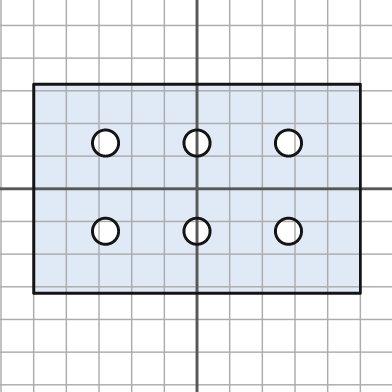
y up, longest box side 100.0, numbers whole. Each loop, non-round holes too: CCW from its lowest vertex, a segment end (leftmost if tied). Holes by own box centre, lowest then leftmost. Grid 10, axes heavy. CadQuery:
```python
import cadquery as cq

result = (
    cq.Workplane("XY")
    .moveTo(-50.0, -32.0)
    .lineTo(50.0, -32.0)
    .lineTo(50.0, 32.0)
    .lineTo(-50.0, 32.0)
    .close()
    .moveTo(-28.0, -13.0)
    .circle(4.0)
    .moveTo(0.0, -13.0)
    .circle(4.0)
    .moveTo(28.0, -13.0)
    .circle(4.0)
    .moveTo(-28.0, 14.0)
    .circle(4.0)
    .moveTo(0.0, 14.0)
    .circle(4.0)
    .moveTo(28.0, 14.0)
    .circle(4.0)
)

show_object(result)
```